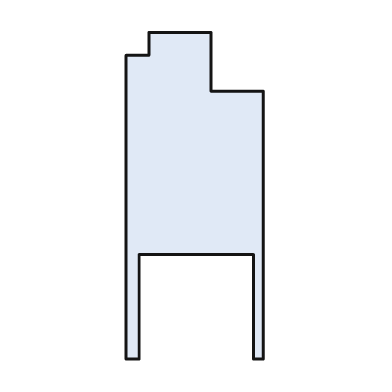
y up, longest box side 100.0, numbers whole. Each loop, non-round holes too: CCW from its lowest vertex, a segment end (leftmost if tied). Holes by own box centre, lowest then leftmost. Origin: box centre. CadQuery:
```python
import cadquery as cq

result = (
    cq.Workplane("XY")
    .moveTo(-21.0, -50.0)
    .lineTo(-17.0, -50.0)
    .lineTo(-17.0, -18.0)
    .lineTo(18.0, -18.0)
    .lineTo(18.0, -50.0)
    .lineTo(21.0, -50.0)
    .lineTo(21.0, 32.0)
    .lineTo(5.0, 32.0)
    .lineTo(5.0, 50.0)
    .lineTo(-14.0, 50.0)
    .lineTo(-14.0, 43.0)
    .lineTo(-21.0, 43.0)
    .close()
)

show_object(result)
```